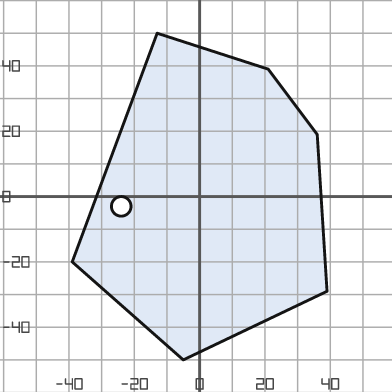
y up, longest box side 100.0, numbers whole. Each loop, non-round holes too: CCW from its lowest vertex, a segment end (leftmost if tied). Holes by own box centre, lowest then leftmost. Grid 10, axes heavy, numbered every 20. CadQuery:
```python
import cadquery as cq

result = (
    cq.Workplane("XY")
    .moveTo(-5.0, -50.0)
    .lineTo(39.0, -29.0)
    .lineTo(36.0, 19.0)
    .lineTo(21.0, 39.0)
    .lineTo(-13.0, 50.0)
    .lineTo(-39.0, -20.0)
    .close()
    .moveTo(-24.0, -3.0)
    .circle(3.0)
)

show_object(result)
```